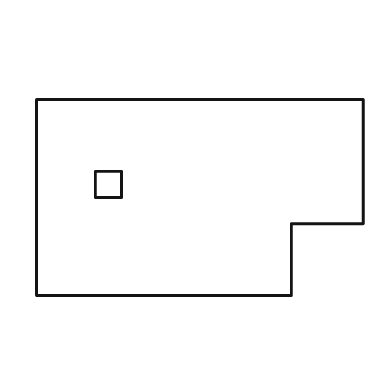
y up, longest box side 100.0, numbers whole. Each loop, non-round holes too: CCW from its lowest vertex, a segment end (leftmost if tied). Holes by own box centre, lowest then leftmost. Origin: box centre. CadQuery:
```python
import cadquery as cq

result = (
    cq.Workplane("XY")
    .moveTo(-50.0, -30.0)
    .lineTo(28.0, -30.0)
    .lineTo(28.0, -8.0)
    .lineTo(50.0, -8.0)
    .lineTo(50.0, 30.0)
    .lineTo(-50.0, 30.0)
    .close()
    .moveTo(-32.0, 0.0)
    .lineTo(-24.0, 0.0)
    .lineTo(-24.0, 8.0)
    .lineTo(-32.0, 8.0)
    .close()
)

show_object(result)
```